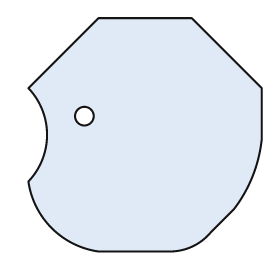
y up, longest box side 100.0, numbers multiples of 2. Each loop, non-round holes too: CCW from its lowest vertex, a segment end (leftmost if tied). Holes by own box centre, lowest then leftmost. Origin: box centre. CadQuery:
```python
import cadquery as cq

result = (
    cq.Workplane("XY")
    .moveTo(-20.0, -50.0)
    .lineTo(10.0, -50.0)
    .threePointArc((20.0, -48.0), (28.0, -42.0))
    .lineTo(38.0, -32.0)
    .threePointArc((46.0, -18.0), (50.0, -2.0))
    .lineTo(50.0, 20.0)
    .lineTo(20.0, 50.0)
    .lineTo(-20.0, 50.0)
    .lineTo(-50.0, 20.0)
    .threePointArc((-42.0, 0.0), (-50.0, -20.0))
    .threePointArc((-40.0, -40.0), (-20.0, -50.0))
    .close()
    .moveTo(-26.0, 8.0)
    .circle(4.0)
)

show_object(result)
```